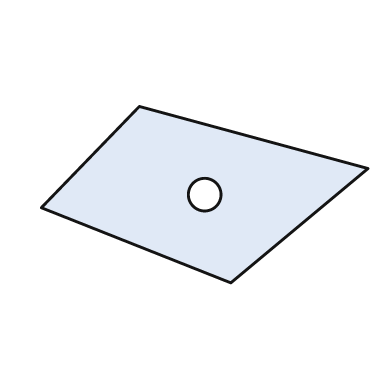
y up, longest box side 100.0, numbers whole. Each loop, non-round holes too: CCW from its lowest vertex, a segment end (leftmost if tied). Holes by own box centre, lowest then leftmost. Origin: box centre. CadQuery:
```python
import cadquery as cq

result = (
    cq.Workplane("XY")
    .moveTo(8.0, -27.0)
    .lineTo(50.0, 8.0)
    .lineTo(-20.0, 27.0)
    .lineTo(-50.0, -4.0)
    .close()
    .moveTo(0.0, 0.0)
    .circle(5.0)
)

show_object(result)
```